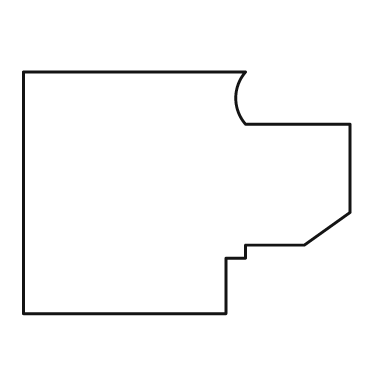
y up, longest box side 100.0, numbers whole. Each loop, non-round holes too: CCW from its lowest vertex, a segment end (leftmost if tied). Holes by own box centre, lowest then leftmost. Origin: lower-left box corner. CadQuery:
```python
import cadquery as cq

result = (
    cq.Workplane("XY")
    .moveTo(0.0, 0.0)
    .lineTo(62.0, 0.0)
    .lineTo(62.0, 17.0)
    .lineTo(68.0, 17.0)
    .lineTo(68.0, 21.0)
    .lineTo(86.0, 21.0)
    .lineTo(100.0, 31.0)
    .lineTo(100.0, 58.0)
    .lineTo(68.0, 58.0)
    .threePointArc((65.0, 66.0), (68.0, 74.0))
    .lineTo(0.0, 74.0)
    .close()
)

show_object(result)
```